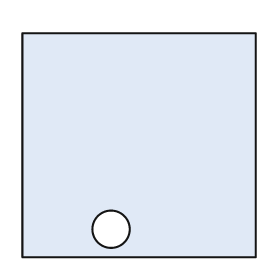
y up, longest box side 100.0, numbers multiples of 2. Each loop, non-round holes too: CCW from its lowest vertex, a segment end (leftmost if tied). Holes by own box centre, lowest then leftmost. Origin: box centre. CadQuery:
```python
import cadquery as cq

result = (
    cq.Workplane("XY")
    .moveTo(-50.0, -48.0)
    .lineTo(50.0, -48.0)
    .lineTo(50.0, 48.0)
    .lineTo(-50.0, 48.0)
    .close()
    .moveTo(-12.0, -36.0)
    .circle(8.0)
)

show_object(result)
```